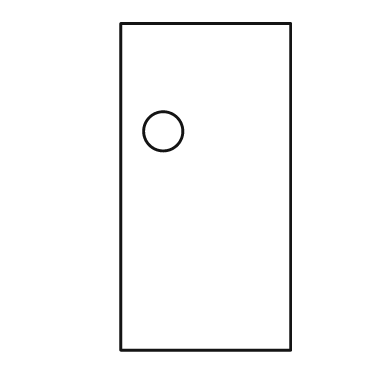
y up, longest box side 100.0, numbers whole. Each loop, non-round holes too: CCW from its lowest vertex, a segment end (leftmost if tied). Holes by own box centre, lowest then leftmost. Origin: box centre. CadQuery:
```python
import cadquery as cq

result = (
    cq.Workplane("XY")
    .moveTo(-26.0, -50.0)
    .lineTo(26.0, -50.0)
    .lineTo(26.0, 50.0)
    .lineTo(-26.0, 50.0)
    .close()
    .moveTo(-13.0, 17.0)
    .circle(6.0)
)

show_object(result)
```